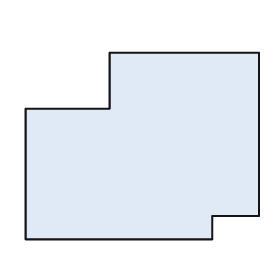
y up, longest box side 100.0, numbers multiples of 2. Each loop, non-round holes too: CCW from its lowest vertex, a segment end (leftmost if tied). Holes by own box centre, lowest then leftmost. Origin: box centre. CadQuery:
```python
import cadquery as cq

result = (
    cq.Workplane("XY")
    .moveTo(-50.0, -40.0)
    .lineTo(30.0, -40.0)
    .lineTo(30.0, -30.0)
    .lineTo(50.0, -30.0)
    .lineTo(50.0, 40.0)
    .lineTo(-14.0, 40.0)
    .lineTo(-14.0, 16.0)
    .lineTo(-50.0, 16.0)
    .close()
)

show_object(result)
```